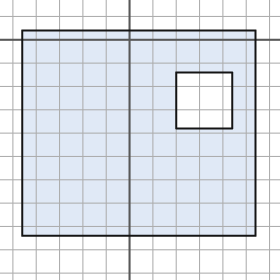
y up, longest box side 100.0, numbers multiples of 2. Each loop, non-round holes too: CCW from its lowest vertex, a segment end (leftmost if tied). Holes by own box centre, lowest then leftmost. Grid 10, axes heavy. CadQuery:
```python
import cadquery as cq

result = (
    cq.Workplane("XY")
    .moveTo(-46.0, -84.0)
    .lineTo(54.0, -84.0)
    .lineTo(54.0, 4.0)
    .lineTo(-46.0, 4.0)
    .close()
    .moveTo(20.0, -38.0)
    .lineTo(44.0, -38.0)
    .lineTo(44.0, -14.0)
    .lineTo(20.0, -14.0)
    .close()
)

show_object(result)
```